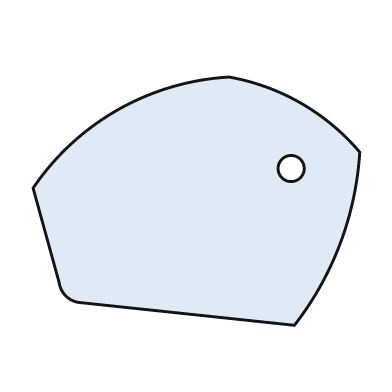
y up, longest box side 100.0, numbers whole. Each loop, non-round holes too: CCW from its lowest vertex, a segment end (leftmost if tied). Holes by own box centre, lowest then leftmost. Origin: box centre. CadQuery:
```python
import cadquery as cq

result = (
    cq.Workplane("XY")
    .moveTo(30.0, -38.0)
    .threePointArc((44.0, -13.0), (50.0, 15.0))
    .threePointArc((32.0, 30.0), (10.0, 38.0))
    .threePointArc((-24.0, 28.0), (-50.0, 4.0))
    .lineTo(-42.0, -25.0)
    .threePointArc((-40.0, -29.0), (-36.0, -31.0))
    .close()
    .moveTo(29.0, 10.0)
    .circle(4.0)
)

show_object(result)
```